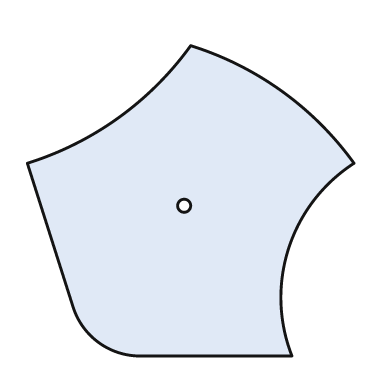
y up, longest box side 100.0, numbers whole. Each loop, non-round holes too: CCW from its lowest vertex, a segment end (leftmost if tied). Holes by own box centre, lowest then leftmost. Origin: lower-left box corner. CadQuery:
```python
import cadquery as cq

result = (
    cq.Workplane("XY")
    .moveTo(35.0, 0.0)
    .lineTo(81.0, 0.0)
    .threePointArc((80.0, 33.0), (100.0, 59.0))
    .threePointArc((78.0, 81.0), (50.0, 95.0))
    .threePointArc((28.0, 73.0), (0.0, 59.0))
    .lineTo(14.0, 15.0)
    .threePointArc((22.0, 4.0), (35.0, 0.0))
    .close()
    .moveTo(48.0, 46.0)
    .circle(2.0)
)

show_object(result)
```